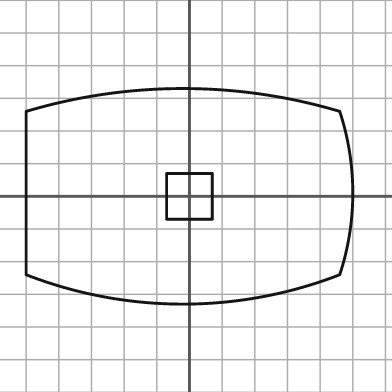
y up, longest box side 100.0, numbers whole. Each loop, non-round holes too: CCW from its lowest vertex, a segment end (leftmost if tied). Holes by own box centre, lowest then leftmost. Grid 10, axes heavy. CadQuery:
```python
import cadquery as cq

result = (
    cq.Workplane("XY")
    .moveTo(-50.0, -24.0)
    .threePointArc((-2.0, -33.0), (46.0, -24.0))
    .threePointArc((50.0, 1.0), (46.0, 26.0))
    .threePointArc((-2.0, 33.0), (-50.0, 26.0))
    .close()
    .moveTo(-7.0, -7.0)
    .lineTo(7.0, -7.0)
    .lineTo(7.0, 7.0)
    .lineTo(-7.0, 7.0)
    .close()
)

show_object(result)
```